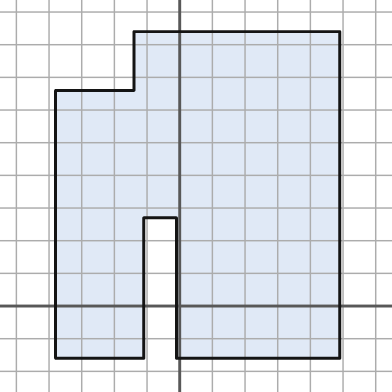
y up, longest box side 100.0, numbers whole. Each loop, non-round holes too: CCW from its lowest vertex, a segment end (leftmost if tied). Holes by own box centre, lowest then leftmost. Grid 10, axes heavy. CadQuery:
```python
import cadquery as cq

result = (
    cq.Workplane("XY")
    .moveTo(-38.0, -16.0)
    .lineTo(-11.0, -16.0)
    .lineTo(-11.0, 27.0)
    .lineTo(-1.0, 27.0)
    .lineTo(-1.0, -16.0)
    .lineTo(49.0, -16.0)
    .lineTo(49.0, 84.0)
    .lineTo(-14.0, 84.0)
    .lineTo(-14.0, 66.0)
    .lineTo(-38.0, 66.0)
    .close()
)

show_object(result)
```